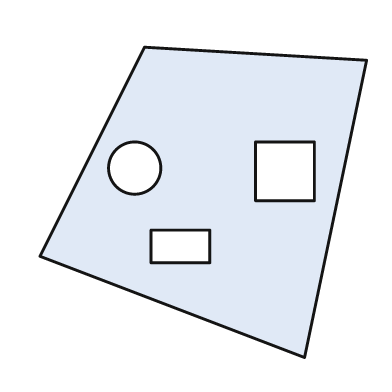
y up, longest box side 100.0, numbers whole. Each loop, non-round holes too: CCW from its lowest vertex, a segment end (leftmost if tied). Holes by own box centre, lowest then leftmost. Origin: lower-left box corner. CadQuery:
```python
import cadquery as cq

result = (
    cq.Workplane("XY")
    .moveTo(81.0, 0.0)
    .lineTo(100.0, 91.0)
    .lineTo(32.0, 95.0)
    .lineTo(0.0, 31.0)
    .close()
    .moveTo(34.0, 29.0)
    .lineTo(52.0, 29.0)
    .lineTo(52.0, 39.0)
    .lineTo(34.0, 39.0)
    .close()
    .moveTo(66.0, 48.0)
    .lineTo(84.0, 48.0)
    .lineTo(84.0, 66.0)
    .lineTo(66.0, 66.0)
    .close()
    .moveTo(29.0, 58.0)
    .circle(8.0)
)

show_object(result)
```